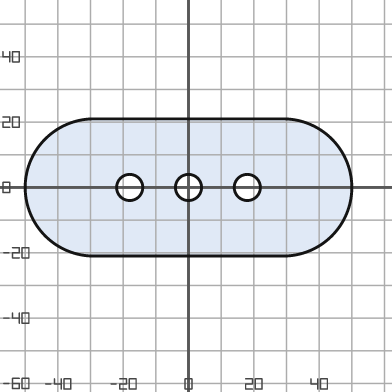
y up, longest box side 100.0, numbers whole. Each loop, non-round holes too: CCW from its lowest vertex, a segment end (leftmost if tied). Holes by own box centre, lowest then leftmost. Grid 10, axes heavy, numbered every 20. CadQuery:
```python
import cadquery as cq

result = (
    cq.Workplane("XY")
    .moveTo(-29.0, -21.0)
    .lineTo(29.0, -21.0)
    .threePointArc((50.0, 0.0), (29.0, 21.0))
    .lineTo(-29.0, 21.0)
    .threePointArc((-50.0, 0.0), (-29.0, -21.0))
    .close()
    .moveTo(-18.0, 0.0)
    .circle(4.0)
    .moveTo(0.0, 0.0)
    .circle(4.0)
    .moveTo(18.0, 0.0)
    .circle(4.0)
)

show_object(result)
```